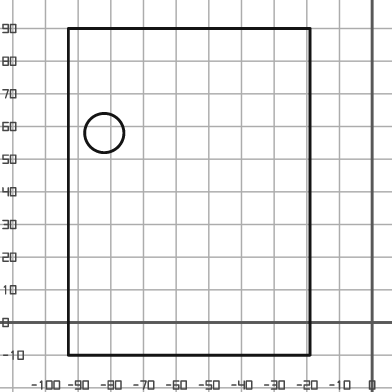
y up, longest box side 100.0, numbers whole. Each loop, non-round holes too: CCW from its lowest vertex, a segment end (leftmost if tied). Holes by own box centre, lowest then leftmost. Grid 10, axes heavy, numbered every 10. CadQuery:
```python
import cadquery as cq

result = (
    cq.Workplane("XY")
    .moveTo(-93.0, -10.0)
    .lineTo(-19.0, -10.0)
    .lineTo(-19.0, 90.0)
    .lineTo(-93.0, 90.0)
    .close()
    .moveTo(-82.0, 58.0)
    .circle(6.0)
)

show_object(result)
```